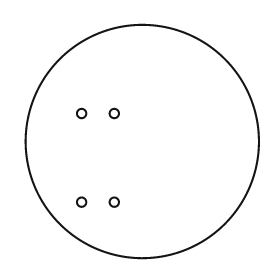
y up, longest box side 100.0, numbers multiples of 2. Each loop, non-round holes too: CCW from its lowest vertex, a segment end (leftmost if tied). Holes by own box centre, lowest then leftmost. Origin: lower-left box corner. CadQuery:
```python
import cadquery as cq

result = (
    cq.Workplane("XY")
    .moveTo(50.0, 50.0)
    .circle(50.0)
    .moveTo(24.0, 24.0)
    .circle(2.0)
    .moveTo(38.0, 24.0)
    .circle(2.0)
    .moveTo(24.0, 62.0)
    .circle(2.0)
    .moveTo(38.0, 62.0)
    .circle(2.0)
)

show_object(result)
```